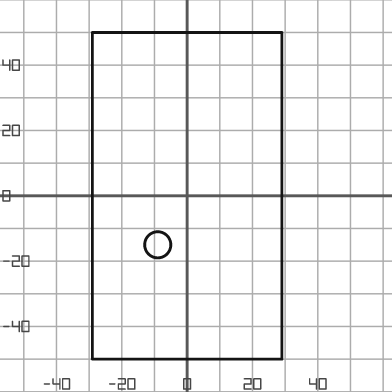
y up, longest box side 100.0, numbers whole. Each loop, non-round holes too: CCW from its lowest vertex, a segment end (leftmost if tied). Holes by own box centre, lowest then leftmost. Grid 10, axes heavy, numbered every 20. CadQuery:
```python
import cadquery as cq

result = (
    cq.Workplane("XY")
    .moveTo(-29.0, -50.0)
    .lineTo(29.0, -50.0)
    .lineTo(29.0, 50.0)
    .lineTo(-29.0, 50.0)
    .close()
    .moveTo(-9.0, -15.0)
    .circle(4.0)
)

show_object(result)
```